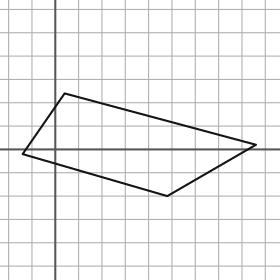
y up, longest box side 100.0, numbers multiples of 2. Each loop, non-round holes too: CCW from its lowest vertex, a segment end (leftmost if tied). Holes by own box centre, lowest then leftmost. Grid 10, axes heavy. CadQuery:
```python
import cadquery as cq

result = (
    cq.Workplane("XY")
    .moveTo(48.0, -20.0)
    .lineTo(86.0, 2.0)
    .lineTo(4.0, 24.0)
    .lineTo(-14.0, -2.0)
    .close()
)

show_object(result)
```